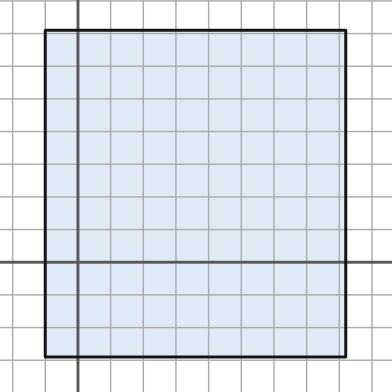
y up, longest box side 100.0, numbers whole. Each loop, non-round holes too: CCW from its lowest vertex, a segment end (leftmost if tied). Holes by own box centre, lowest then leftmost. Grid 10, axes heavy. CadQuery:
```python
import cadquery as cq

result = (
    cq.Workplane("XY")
    .moveTo(-10.0, -29.0)
    .lineTo(82.0, -29.0)
    .lineTo(82.0, 71.0)
    .lineTo(-10.0, 71.0)
    .close()
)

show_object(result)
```